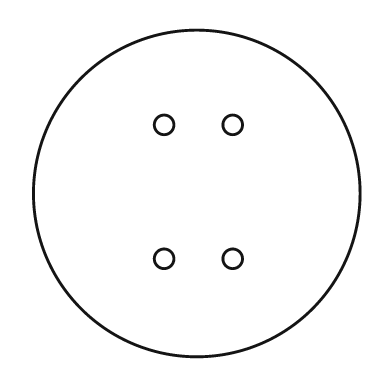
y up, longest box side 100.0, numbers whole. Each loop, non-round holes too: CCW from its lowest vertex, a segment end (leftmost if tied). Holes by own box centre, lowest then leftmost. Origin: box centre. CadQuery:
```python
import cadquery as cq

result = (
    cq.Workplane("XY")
    .moveTo(0.0, 0.0)
    .circle(50.0)
    .moveTo(-10.0, -20.0)
    .circle(3.0)
    .moveTo(11.0, -20.0)
    .circle(3.0)
    .moveTo(-10.0, 21.0)
    .circle(3.0)
    .moveTo(11.0, 21.0)
    .circle(3.0)
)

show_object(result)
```